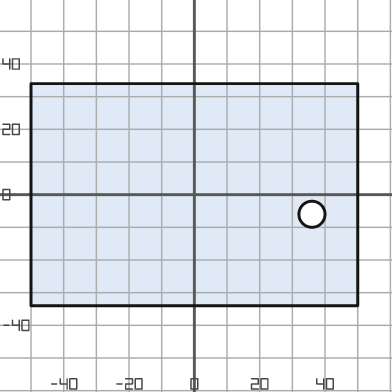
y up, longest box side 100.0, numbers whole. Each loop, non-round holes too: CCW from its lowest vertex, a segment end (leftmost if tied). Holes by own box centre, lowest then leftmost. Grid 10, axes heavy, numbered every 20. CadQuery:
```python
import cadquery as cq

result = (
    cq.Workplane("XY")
    .moveTo(-50.0, -34.0)
    .lineTo(50.0, -34.0)
    .lineTo(50.0, 34.0)
    .lineTo(-50.0, 34.0)
    .close()
    .moveTo(36.0, -6.0)
    .circle(4.0)
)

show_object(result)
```